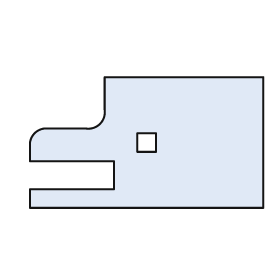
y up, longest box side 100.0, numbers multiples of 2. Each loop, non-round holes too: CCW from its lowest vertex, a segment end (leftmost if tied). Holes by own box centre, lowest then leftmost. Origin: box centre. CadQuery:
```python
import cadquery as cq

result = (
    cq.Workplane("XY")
    .moveTo(-50.0, -28.0)
    .lineTo(50.0, -28.0)
    .lineTo(50.0, 28.0)
    .lineTo(-18.0, 28.0)
    .lineTo(-18.0, 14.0)
    .threePointArc((-20.0, 8.0), (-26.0, 6.0))
    .lineTo(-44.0, 6.0)
    .threePointArc((-48.0, 4.0), (-50.0, 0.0))
    .lineTo(-50.0, -8.0)
    .lineTo(-14.0, -8.0)
    .lineTo(-14.0, -20.0)
    .lineTo(-50.0, -20.0)
    .close()
    .moveTo(-4.0, -4.0)
    .lineTo(4.0, -4.0)
    .lineTo(4.0, 4.0)
    .lineTo(-4.0, 4.0)
    .close()
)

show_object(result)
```